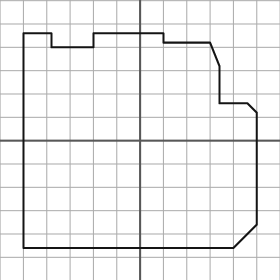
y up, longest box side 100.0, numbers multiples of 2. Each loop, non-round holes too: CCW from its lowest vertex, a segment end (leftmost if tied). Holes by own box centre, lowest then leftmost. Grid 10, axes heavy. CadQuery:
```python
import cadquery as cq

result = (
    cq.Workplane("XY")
    .moveTo(-50.0, -46.0)
    .lineTo(40.0, -46.0)
    .lineTo(50.0, -36.0)
    .lineTo(50.0, 12.0)
    .lineTo(46.0, 16.0)
    .lineTo(34.0, 16.0)
    .lineTo(34.0, 32.0)
    .lineTo(30.0, 42.0)
    .lineTo(10.0, 42.0)
    .lineTo(10.0, 46.0)
    .lineTo(-20.0, 46.0)
    .lineTo(-20.0, 40.0)
    .lineTo(-38.0, 40.0)
    .lineTo(-38.0, 46.0)
    .lineTo(-50.0, 46.0)
    .close()
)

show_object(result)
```